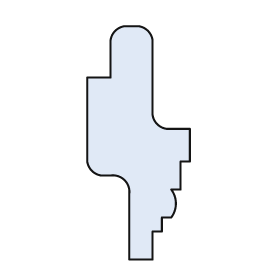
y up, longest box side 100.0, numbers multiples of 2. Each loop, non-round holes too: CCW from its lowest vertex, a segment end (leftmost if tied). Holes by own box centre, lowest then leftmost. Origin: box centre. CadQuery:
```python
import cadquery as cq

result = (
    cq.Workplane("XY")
    .moveTo(-4.0, -50.0)
    .lineTo(6.0, -50.0)
    .lineTo(6.0, -38.0)
    .lineTo(10.0, -38.0)
    .lineTo(10.0, -32.0)
    .lineTo(14.0, -32.0)
    .threePointArc((16.0, -26.0), (14.0, -20.0))
    .lineTo(18.0, -20.0)
    .lineTo(18.0, -8.0)
    .lineTo(22.0, -8.0)
    .lineTo(22.0, 6.0)
    .lineTo(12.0, 6.0)
    .threePointArc((8.0, 8.0), (6.0, 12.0))
    .lineTo(6.0, 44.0)
    .threePointArc((4.0, 48.0), (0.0, 50.0))
    .lineTo(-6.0, 50.0)
    .threePointArc((-10.0, 48.0), (-12.0, 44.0))
    .lineTo(-12.0, 28.0)
    .lineTo(-22.0, 28.0)
    .lineTo(-22.0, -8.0)
    .threePointArc((-20.0, -12.0), (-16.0, -14.0))
    .lineTo(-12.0, -14.0)
    .threePointArc((-6.0, -16.0), (-4.0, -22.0))
    .close()
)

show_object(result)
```